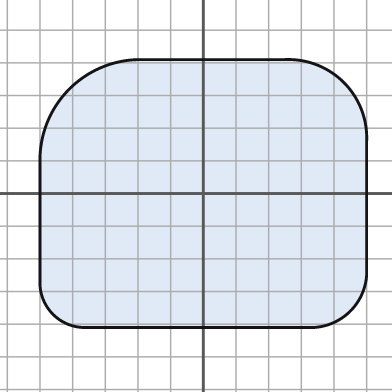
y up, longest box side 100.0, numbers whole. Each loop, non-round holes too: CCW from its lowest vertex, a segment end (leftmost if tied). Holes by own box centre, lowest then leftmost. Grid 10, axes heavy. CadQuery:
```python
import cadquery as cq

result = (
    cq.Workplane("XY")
    .moveTo(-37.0, -41.0)
    .lineTo(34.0, -41.0)
    .threePointArc((45.0, -36.0), (50.0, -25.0))
    .lineTo(50.0, 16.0)
    .threePointArc((43.0, 34.0), (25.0, 41.0))
    .lineTo(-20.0, 41.0)
    .threePointArc((-41.0, 32.0), (-50.0, 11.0))
    .lineTo(-50.0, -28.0)
    .threePointArc((-46.0, -37.0), (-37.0, -41.0))
    .close()
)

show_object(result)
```